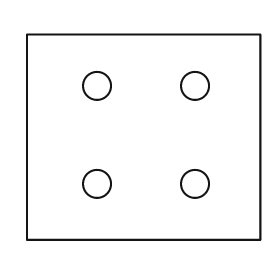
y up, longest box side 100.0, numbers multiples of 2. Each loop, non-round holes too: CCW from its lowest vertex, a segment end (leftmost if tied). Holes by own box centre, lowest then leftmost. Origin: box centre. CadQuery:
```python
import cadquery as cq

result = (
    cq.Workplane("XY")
    .moveTo(-50.0, -44.0)
    .lineTo(50.0, -44.0)
    .lineTo(50.0, 44.0)
    .lineTo(-50.0, 44.0)
    .close()
    .moveTo(-20.0, -20.0)
    .circle(6.0)
    .moveTo(22.0, -20.0)
    .circle(6.0)
    .moveTo(-20.0, 22.0)
    .circle(6.0)
    .moveTo(22.0, 22.0)
    .circle(6.0)
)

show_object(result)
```